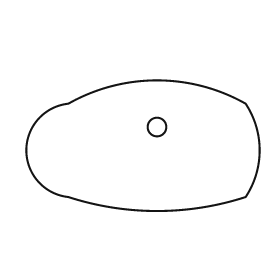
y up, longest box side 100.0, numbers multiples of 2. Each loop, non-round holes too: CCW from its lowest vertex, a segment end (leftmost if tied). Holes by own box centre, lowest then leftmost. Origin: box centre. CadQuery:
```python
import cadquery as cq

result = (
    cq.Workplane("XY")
    .moveTo(-32.0, -22.0)
    .threePointArc((6.0, -28.0), (44.0, -22.0))
    .threePointArc((50.0, -2.0), (44.0, 18.0))
    .threePointArc((6.0, 28.0), (-32.0, 18.0))
    .threePointArc((-50.0, -2.0), (-32.0, -22.0))
    .close()
    .moveTo(6.0, 8.0)
    .circle(4.0)
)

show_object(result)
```